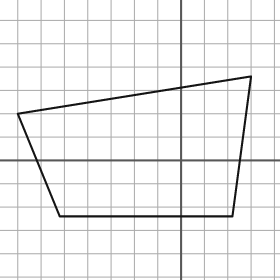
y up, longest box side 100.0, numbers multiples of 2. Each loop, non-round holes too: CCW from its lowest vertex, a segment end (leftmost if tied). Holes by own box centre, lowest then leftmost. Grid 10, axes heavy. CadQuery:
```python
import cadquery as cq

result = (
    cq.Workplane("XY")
    .moveTo(-52.0, -24.0)
    .lineTo(22.0, -24.0)
    .lineTo(30.0, 36.0)
    .lineTo(-70.0, 20.0)
    .close()
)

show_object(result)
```